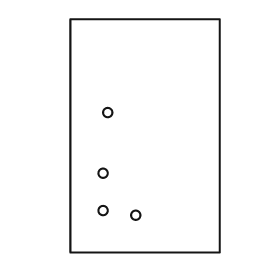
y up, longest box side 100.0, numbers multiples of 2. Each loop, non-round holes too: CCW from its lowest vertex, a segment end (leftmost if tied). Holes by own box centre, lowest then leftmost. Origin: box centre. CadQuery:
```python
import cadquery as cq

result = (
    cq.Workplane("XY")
    .moveTo(-32.0, -50.0)
    .lineTo(32.0, -50.0)
    .lineTo(32.0, 50.0)
    .lineTo(-32.0, 50.0)
    .close()
    .moveTo(-4.0, -34.0)
    .circle(2.0)
    .moveTo(-18.0, -32.0)
    .circle(2.0)
    .moveTo(-18.0, -16.0)
    .circle(2.0)
    .moveTo(-16.0, 10.0)
    .circle(2.0)
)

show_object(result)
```